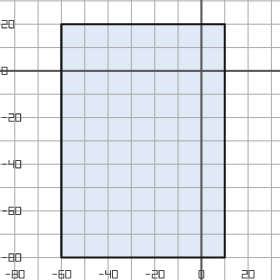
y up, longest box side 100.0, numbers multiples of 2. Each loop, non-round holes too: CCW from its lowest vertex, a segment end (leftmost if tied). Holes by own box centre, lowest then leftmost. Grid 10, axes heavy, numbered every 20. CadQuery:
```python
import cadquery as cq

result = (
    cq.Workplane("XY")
    .moveTo(-60.0, -80.0)
    .lineTo(10.0, -80.0)
    .lineTo(10.0, 20.0)
    .lineTo(-60.0, 20.0)
    .close()
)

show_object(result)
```